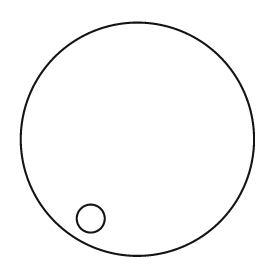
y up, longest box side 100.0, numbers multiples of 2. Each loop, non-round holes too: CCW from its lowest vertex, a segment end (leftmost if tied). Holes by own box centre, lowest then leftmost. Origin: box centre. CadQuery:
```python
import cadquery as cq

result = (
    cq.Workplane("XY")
    .moveTo(0.0, 0.0)
    .circle(50.0)
    .moveTo(-20.0, -34.0)
    .circle(6.0)
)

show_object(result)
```